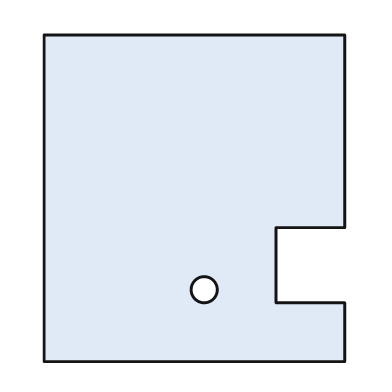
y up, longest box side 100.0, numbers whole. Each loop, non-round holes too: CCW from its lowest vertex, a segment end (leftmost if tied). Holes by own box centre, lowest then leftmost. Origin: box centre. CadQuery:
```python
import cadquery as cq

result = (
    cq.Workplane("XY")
    .moveTo(-46.0, -50.0)
    .lineTo(46.0, -50.0)
    .lineTo(46.0, -32.0)
    .lineTo(25.0, -32.0)
    .lineTo(25.0, -9.0)
    .lineTo(46.0, -9.0)
    .lineTo(46.0, 50.0)
    .lineTo(-46.0, 50.0)
    .close()
    .moveTo(3.0, -28.0)
    .circle(4.0)
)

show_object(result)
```